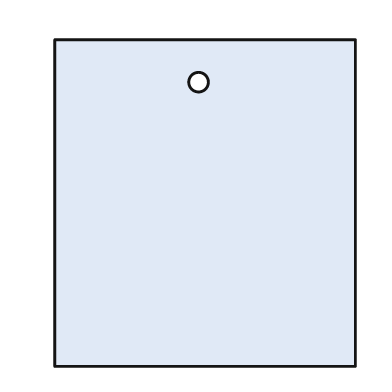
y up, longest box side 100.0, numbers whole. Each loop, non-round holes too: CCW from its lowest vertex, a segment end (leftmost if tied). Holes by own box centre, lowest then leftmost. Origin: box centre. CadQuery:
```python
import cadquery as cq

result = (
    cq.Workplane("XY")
    .moveTo(-46.0, -50.0)
    .lineTo(46.0, -50.0)
    .lineTo(46.0, 50.0)
    .lineTo(-46.0, 50.0)
    .close()
    .moveTo(-2.0, 37.0)
    .circle(3.0)
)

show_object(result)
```